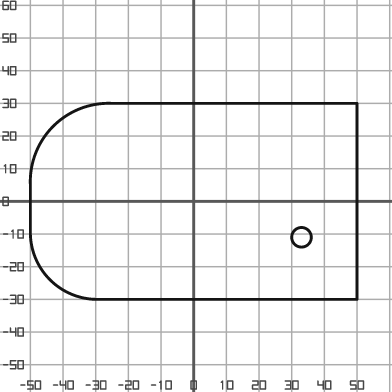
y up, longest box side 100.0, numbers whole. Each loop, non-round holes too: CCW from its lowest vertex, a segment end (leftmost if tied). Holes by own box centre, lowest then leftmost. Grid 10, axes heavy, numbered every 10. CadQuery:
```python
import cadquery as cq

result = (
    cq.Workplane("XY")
    .moveTo(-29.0, -30.0)
    .lineTo(50.0, -30.0)
    .lineTo(50.0, 30.0)
    .lineTo(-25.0, 30.0)
    .threePointArc((-43.0, 23.0), (-50.0, 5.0))
    .lineTo(-50.0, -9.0)
    .threePointArc((-44.0, -24.0), (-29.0, -30.0))
    .close()
    .moveTo(33.0, -11.0)
    .circle(3.0)
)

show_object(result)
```